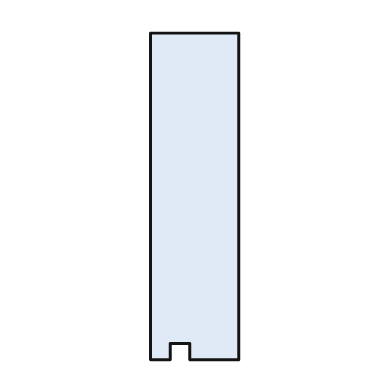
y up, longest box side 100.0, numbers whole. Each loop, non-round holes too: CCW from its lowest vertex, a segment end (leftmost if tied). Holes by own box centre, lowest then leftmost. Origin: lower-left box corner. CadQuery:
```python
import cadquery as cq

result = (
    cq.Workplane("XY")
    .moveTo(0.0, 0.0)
    .lineTo(6.0, 0.0)
    .lineTo(6.0, 5.0)
    .lineTo(12.0, 5.0)
    .lineTo(12.0, 0.0)
    .lineTo(27.0, 0.0)
    .lineTo(27.0, 100.0)
    .lineTo(0.0, 100.0)
    .close()
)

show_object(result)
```